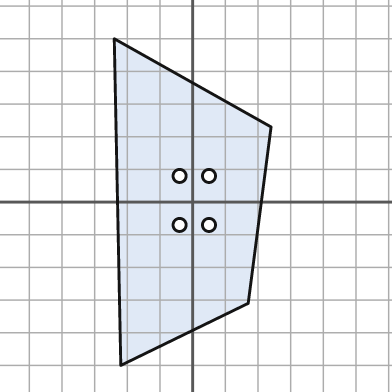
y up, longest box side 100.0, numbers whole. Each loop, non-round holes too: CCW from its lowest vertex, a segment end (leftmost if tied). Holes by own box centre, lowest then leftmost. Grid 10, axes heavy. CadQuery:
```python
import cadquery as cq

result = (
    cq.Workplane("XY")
    .moveTo(-22.0, -50.0)
    .lineTo(17.0, -31.0)
    .lineTo(24.0, 23.0)
    .lineTo(-24.0, 50.0)
    .close()
    .moveTo(-4.0, -7.0)
    .circle(2.0)
    .moveTo(5.0, -7.0)
    .circle(2.0)
    .moveTo(-4.0, 8.0)
    .circle(2.0)
    .moveTo(5.0, 8.0)
    .circle(2.0)
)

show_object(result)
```